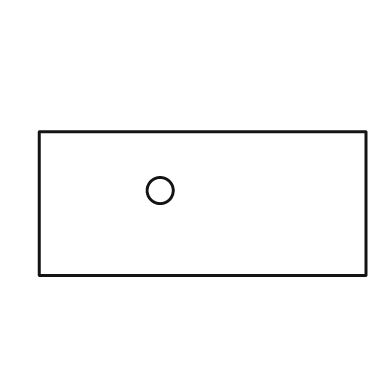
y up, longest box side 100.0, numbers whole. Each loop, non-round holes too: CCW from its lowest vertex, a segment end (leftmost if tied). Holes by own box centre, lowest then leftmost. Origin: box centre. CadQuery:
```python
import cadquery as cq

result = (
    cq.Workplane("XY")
    .moveTo(-50.0, -22.0)
    .lineTo(50.0, -22.0)
    .lineTo(50.0, 22.0)
    .lineTo(-50.0, 22.0)
    .close()
    .moveTo(-13.0, 4.0)
    .circle(4.0)
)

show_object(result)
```